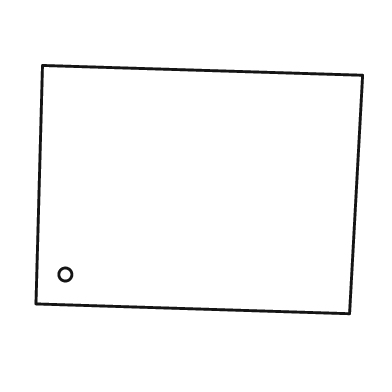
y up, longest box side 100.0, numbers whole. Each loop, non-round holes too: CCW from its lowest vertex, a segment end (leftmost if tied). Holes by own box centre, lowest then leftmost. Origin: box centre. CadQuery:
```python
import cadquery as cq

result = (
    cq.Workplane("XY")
    .moveTo(46.0, -38.0)
    .lineTo(50.0, 35.0)
    .lineTo(-48.0, 38.0)
    .lineTo(-50.0, -35.0)
    .close()
    .moveTo(-41.0, -26.0)
    .circle(2.0)
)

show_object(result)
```